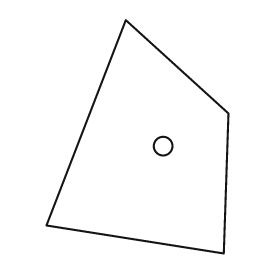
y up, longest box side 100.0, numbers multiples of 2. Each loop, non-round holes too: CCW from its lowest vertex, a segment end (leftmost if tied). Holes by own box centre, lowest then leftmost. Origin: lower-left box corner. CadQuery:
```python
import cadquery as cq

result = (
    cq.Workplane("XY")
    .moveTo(76.0, 0.0)
    .lineTo(78.0, 60.0)
    .lineTo(34.0, 100.0)
    .lineTo(0.0, 12.0)
    .close()
    .moveTo(50.0, 46.0)
    .circle(4.0)
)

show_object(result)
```